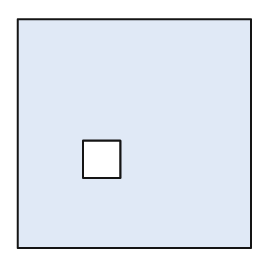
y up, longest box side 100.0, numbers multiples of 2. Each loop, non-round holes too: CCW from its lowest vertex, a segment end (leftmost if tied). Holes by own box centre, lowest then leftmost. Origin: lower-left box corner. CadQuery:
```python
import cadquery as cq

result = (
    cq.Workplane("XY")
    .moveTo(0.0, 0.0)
    .lineTo(100.0, 0.0)
    .lineTo(100.0, 98.0)
    .lineTo(0.0, 98.0)
    .close()
    .moveTo(28.0, 30.0)
    .lineTo(44.0, 30.0)
    .lineTo(44.0, 46.0)
    .lineTo(28.0, 46.0)
    .close()
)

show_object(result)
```